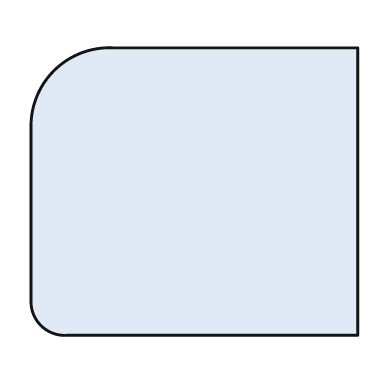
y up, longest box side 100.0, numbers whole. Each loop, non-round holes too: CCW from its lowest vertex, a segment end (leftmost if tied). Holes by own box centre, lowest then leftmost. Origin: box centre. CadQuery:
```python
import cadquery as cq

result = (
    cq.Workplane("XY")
    .moveTo(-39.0, -44.0)
    .lineTo(50.0, -44.0)
    .lineTo(50.0, 44.0)
    .lineTo(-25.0, 44.0)
    .threePointArc((-43.0, 37.0), (-50.0, 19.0))
    .lineTo(-50.0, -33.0)
    .threePointArc((-47.0, -41.0), (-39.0, -44.0))
    .close()
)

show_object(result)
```